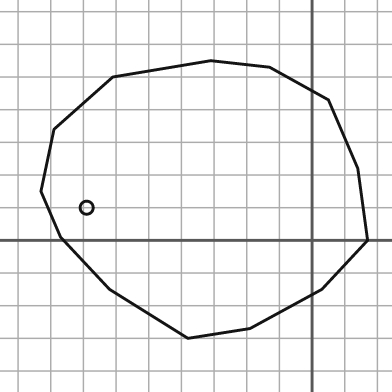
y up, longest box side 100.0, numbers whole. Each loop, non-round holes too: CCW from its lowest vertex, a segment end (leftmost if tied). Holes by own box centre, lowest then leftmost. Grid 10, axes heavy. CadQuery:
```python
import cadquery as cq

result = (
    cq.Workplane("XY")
    .moveTo(-38.0, -30.0)
    .lineTo(-19.0, -27.0)
    .lineTo(3.0, -15.0)
    .lineTo(17.0, 0.0)
    .lineTo(14.0, 22.0)
    .lineTo(5.0, 43.0)
    .lineTo(-13.0, 53.0)
    .lineTo(-31.0, 55.0)
    .lineTo(-61.0, 50.0)
    .lineTo(-79.0, 34.0)
    .lineTo(-83.0, 15.0)
    .lineTo(-77.0, 1.0)
    .lineTo(-62.0, -15.0)
    .close()
    .moveTo(-69.0, 10.0)
    .circle(2.0)
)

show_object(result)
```